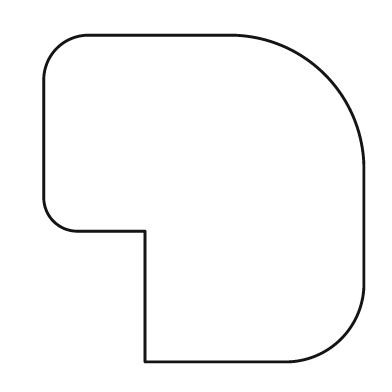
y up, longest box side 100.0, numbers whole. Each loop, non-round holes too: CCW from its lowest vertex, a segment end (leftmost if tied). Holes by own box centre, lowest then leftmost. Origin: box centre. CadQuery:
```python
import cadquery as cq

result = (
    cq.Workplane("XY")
    .moveTo(-18.0, -50.0)
    .lineTo(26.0, -50.0)
    .threePointArc((42.0, -43.0), (49.0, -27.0))
    .lineTo(49.0, 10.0)
    .threePointArc((37.0, 38.0), (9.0, 50.0))
    .lineTo(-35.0, 50.0)
    .threePointArc((-45.0, 46.0), (-49.0, 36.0))
    .lineTo(-49.0, 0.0)
    .threePointArc((-46.0, -7.0), (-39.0, -10.0))
    .lineTo(-18.0, -10.0)
    .close()
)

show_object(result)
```